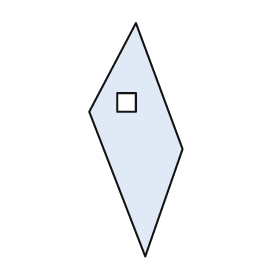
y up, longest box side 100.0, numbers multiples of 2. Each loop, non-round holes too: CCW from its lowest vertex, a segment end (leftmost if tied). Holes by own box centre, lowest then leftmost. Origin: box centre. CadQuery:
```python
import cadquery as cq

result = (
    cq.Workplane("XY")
    .moveTo(4.0, -50.0)
    .lineTo(20.0, -4.0)
    .lineTo(0.0, 50.0)
    .lineTo(-20.0, 12.0)
    .close()
    .moveTo(-8.0, 12.0)
    .lineTo(0.0, 12.0)
    .lineTo(0.0, 20.0)
    .lineTo(-8.0, 20.0)
    .close()
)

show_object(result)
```